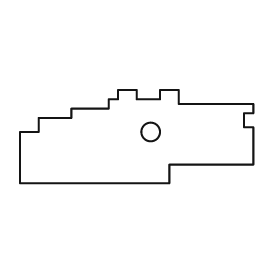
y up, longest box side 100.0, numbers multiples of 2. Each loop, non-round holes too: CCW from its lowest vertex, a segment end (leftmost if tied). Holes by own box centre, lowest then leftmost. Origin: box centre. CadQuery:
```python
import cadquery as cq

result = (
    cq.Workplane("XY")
    .moveTo(-50.0, -20.0)
    .lineTo(14.0, -20.0)
    .lineTo(14.0, -12.0)
    .lineTo(50.0, -12.0)
    .lineTo(50.0, 4.0)
    .lineTo(46.0, 4.0)
    .lineTo(46.0, 10.0)
    .lineTo(50.0, 10.0)
    .lineTo(50.0, 14.0)
    .lineTo(18.0, 14.0)
    .lineTo(18.0, 20.0)
    .lineTo(10.0, 20.0)
    .lineTo(10.0, 16.0)
    .lineTo(0.0, 16.0)
    .lineTo(0.0, 20.0)
    .lineTo(-8.0, 20.0)
    .lineTo(-8.0, 16.0)
    .lineTo(-12.0, 16.0)
    .lineTo(-12.0, 12.0)
    .lineTo(-28.0, 12.0)
    .lineTo(-28.0, 8.0)
    .lineTo(-42.0, 8.0)
    .lineTo(-42.0, 2.0)
    .lineTo(-50.0, 2.0)
    .close()
    .moveTo(6.0, 2.0)
    .circle(4.0)
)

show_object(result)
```